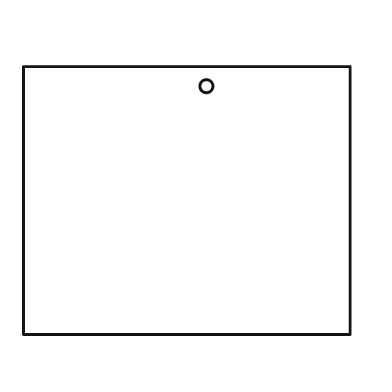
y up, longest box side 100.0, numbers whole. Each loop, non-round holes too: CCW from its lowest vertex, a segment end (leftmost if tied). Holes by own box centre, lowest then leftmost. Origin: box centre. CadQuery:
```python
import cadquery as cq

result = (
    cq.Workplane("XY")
    .moveTo(-50.0, -41.0)
    .lineTo(50.0, -41.0)
    .lineTo(50.0, 41.0)
    .lineTo(-50.0, 41.0)
    .close()
    .moveTo(6.0, 35.0)
    .circle(2.0)
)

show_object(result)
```